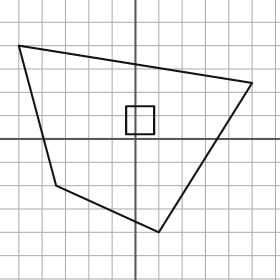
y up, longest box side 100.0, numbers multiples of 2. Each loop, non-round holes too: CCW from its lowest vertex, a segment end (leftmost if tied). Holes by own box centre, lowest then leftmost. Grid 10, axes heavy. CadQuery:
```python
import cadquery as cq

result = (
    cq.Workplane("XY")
    .moveTo(10.0, -40.0)
    .lineTo(50.0, 24.0)
    .lineTo(-50.0, 40.0)
    .lineTo(-34.0, -20.0)
    .close()
    .moveTo(-4.0, 2.0)
    .lineTo(8.0, 2.0)
    .lineTo(8.0, 14.0)
    .lineTo(-4.0, 14.0)
    .close()
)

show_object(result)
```